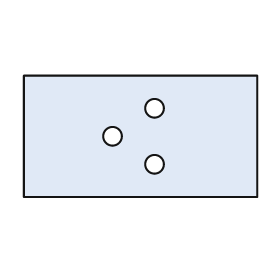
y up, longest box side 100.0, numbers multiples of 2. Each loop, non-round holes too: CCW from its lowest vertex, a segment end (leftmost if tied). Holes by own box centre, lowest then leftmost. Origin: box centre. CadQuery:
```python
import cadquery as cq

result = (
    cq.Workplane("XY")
    .moveTo(-50.0, -26.0)
    .lineTo(50.0, -26.0)
    .lineTo(50.0, 26.0)
    .lineTo(-50.0, 26.0)
    .close()
    .moveTo(6.0, -12.0)
    .circle(4.0)
    .moveTo(-12.0, 0.0)
    .circle(4.0)
    .moveTo(6.0, 12.0)
    .circle(4.0)
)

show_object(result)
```